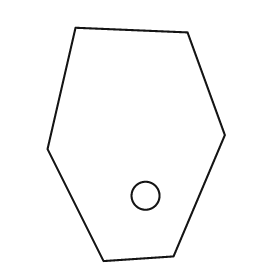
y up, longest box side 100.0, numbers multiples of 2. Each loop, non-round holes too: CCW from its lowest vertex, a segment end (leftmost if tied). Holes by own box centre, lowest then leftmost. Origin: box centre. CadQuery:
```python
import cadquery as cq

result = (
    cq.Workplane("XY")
    .moveTo(-14.0, -50.0)
    .lineTo(16.0, -48.0)
    .lineTo(38.0, 4.0)
    .lineTo(22.0, 48.0)
    .lineTo(-26.0, 50.0)
    .lineTo(-38.0, -2.0)
    .close()
    .moveTo(4.0, -22.0)
    .circle(6.0)
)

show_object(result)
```